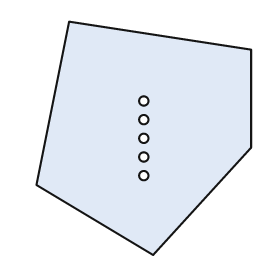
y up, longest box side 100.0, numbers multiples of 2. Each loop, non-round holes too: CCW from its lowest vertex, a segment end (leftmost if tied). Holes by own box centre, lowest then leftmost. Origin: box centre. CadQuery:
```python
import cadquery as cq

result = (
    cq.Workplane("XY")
    .moveTo(4.0, -50.0)
    .lineTo(46.0, -4.0)
    .lineTo(46.0, 38.0)
    .lineTo(-32.0, 50.0)
    .lineTo(-46.0, -20.0)
    .close()
    .moveTo(0.0, -16.0)
    .circle(2.0)
    .moveTo(0.0, -8.0)
    .circle(2.0)
    .moveTo(0.0, 0.0)
    .circle(2.0)
    .moveTo(0.0, 8.0)
    .circle(2.0)
    .moveTo(0.0, 16.0)
    .circle(2.0)
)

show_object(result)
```